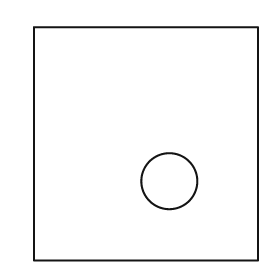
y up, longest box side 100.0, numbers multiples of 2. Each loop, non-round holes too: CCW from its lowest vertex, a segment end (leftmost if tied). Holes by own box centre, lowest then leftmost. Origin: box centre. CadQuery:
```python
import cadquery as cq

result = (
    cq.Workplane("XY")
    .moveTo(-48.0, -50.0)
    .lineTo(48.0, -50.0)
    .lineTo(48.0, 50.0)
    .lineTo(-48.0, 50.0)
    .close()
    .moveTo(10.0, -16.0)
    .circle(12.0)
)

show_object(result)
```